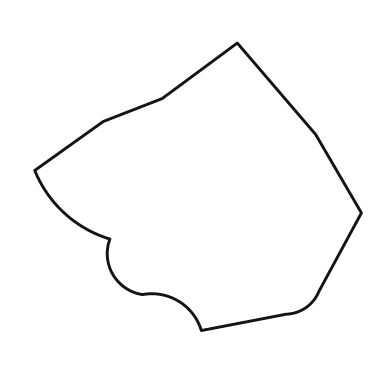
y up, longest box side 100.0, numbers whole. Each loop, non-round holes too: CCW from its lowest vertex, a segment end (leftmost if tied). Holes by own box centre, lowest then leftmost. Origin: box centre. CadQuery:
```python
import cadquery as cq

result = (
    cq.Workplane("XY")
    .moveTo(1.0, -44.0)
    .lineTo(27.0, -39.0)
    .threePointArc((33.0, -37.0), (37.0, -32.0))
    .lineTo(50.0, -8.0)
    .lineTo(36.0, 16.0)
    .lineTo(12.0, 44.0)
    .lineTo(-11.0, 27.0)
    .lineTo(-29.0, 20.0)
    .lineTo(-50.0, 5.0)
    .threePointArc((-41.0, -8.0), (-27.0, -16.0))
    .threePointArc((-26.0, -27.0), (-17.0, -33.0))
    .threePointArc((-6.0, -35.0), (1.0, -44.0))
    .close()
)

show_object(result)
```